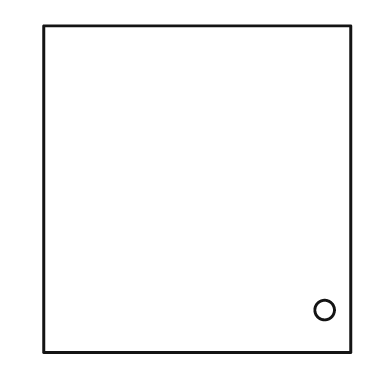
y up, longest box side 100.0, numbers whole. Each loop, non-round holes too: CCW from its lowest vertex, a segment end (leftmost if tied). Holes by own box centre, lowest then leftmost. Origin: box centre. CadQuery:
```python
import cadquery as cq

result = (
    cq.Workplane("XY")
    .moveTo(-47.0, -50.0)
    .lineTo(47.0, -50.0)
    .lineTo(47.0, 50.0)
    .lineTo(-47.0, 50.0)
    .close()
    .moveTo(39.0, -37.0)
    .circle(3.0)
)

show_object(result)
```